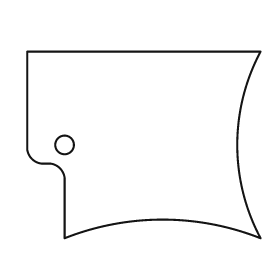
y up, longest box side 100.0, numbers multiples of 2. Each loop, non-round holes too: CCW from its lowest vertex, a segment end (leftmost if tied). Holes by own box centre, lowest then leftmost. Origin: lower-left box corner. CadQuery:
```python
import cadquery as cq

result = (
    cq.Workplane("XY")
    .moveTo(16.0, 0.0)
    .threePointArc((58.0, 8.0), (100.0, 0.0))
    .threePointArc((90.0, 40.0), (100.0, 80.0))
    .lineTo(0.0, 80.0)
    .lineTo(0.0, 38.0)
    .threePointArc((2.0, 34.0), (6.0, 32.0))
    .lineTo(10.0, 32.0)
    .threePointArc((14.0, 30.0), (16.0, 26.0))
    .close()
    .moveTo(16.0, 40.0)
    .circle(4.0)
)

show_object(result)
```